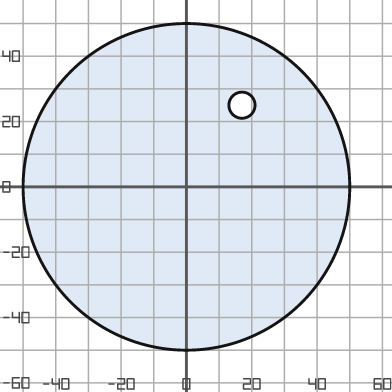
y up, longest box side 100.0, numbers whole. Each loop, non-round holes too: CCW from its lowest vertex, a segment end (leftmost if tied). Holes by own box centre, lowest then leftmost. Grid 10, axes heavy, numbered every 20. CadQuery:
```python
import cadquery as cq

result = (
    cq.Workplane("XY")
    .moveTo(0.0, 0.0)
    .circle(50.0)
    .moveTo(17.0, 25.0)
    .circle(4.0)
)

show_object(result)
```